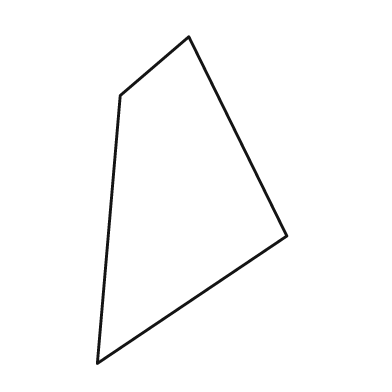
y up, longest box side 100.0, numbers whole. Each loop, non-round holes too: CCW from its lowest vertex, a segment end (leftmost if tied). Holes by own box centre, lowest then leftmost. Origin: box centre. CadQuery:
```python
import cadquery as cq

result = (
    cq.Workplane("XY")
    .moveTo(-29.0, -50.0)
    .lineTo(29.0, -11.0)
    .lineTo(-1.0, 50.0)
    .lineTo(-22.0, 32.0)
    .close()
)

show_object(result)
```